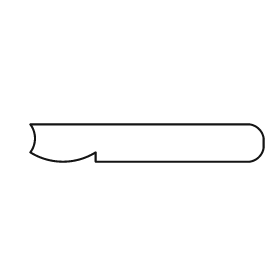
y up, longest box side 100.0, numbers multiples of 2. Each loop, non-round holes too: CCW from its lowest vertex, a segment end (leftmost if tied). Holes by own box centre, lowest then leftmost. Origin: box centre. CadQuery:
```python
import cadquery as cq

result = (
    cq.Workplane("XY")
    .moveTo(-22.0, -8.0)
    .lineTo(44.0, -8.0)
    .threePointArc((48.0, -6.0), (50.0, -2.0))
    .lineTo(50.0, 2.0)
    .threePointArc((48.0, 6.0), (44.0, 8.0))
    .lineTo(-50.0, 8.0)
    .threePointArc((-48.0, 2.0), (-50.0, -4.0))
    .threePointArc((-36.0, -8.0), (-22.0, -4.0))
    .close()
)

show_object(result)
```